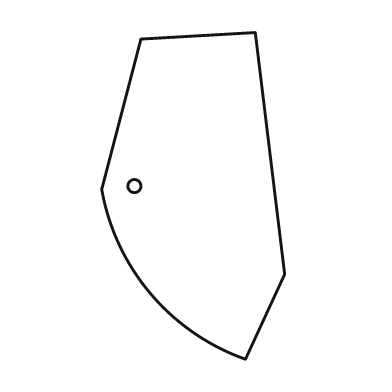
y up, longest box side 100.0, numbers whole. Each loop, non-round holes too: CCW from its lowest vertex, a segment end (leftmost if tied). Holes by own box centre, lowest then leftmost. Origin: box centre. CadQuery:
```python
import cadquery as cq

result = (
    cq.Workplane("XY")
    .moveTo(16.0, -50.0)
    .lineTo(28.0, -24.0)
    .lineTo(19.0, 50.0)
    .lineTo(-16.0, 48.0)
    .lineTo(-28.0, 2.0)
    .threePointArc((-13.0, -30.0), (16.0, -50.0))
    .close()
    .moveTo(-18.0, 3.0)
    .circle(2.0)
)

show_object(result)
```